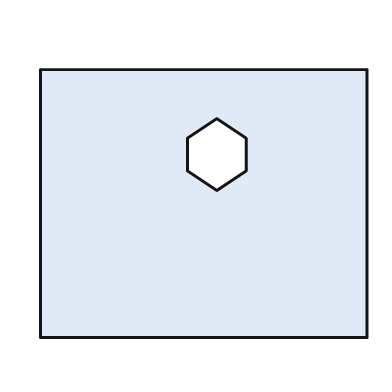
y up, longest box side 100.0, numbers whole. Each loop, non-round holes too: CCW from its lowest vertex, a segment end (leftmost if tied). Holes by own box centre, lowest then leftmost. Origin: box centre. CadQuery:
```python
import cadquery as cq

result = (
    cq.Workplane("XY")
    .moveTo(-50.0, -41.0)
    .lineTo(50.0, -41.0)
    .lineTo(50.0, 41.0)
    .lineTo(-50.0, 41.0)
    .close()
    .moveTo(4.0, 4.0)
    .lineTo(13.0, 10.0)
    .lineTo(13.0, 20.0)
    .lineTo(4.0, 26.0)
    .lineTo(-5.0, 20.0)
    .lineTo(-5.0, 10.0)
    .close()
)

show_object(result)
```